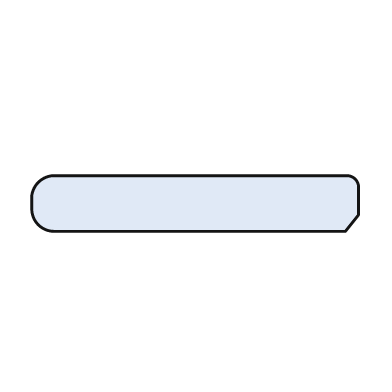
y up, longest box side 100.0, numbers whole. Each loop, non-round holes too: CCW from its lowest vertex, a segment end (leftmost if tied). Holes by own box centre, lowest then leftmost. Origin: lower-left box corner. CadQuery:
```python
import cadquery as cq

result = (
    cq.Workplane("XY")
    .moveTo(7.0, 0.0)
    .lineTo(96.0, 0.0)
    .lineTo(100.0, 5.0)
    .lineTo(100.0, 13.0)
    .threePointArc((99.0, 16.0), (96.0, 17.0))
    .lineTo(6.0, 17.0)
    .threePointArc((2.0, 15.0), (0.0, 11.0))
    .lineTo(0.0, 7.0)
    .threePointArc((2.0, 2.0), (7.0, 0.0))
    .close()
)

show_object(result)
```